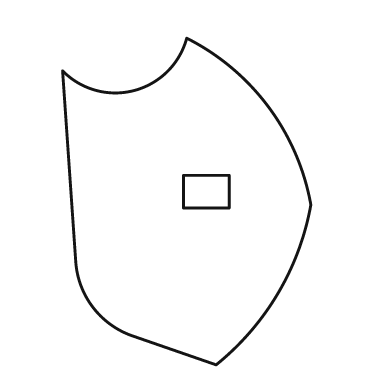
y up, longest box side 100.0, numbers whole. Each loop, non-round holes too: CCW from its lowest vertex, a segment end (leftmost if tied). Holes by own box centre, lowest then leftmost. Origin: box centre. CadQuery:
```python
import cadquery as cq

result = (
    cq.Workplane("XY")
    .moveTo(9.0, -50.0)
    .threePointArc((28.0, -28.0), (38.0, -1.0))
    .threePointArc((25.0, 29.0), (0.0, 50.0))
    .threePointArc((-16.0, 34.0), (-38.0, 40.0))
    .lineTo(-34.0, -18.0)
    .threePointArc((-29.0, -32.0), (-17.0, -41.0))
    .close()
    .moveTo(-1.0, -2.0)
    .lineTo(13.0, -2.0)
    .lineTo(13.0, 8.0)
    .lineTo(-1.0, 8.0)
    .close()
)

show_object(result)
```